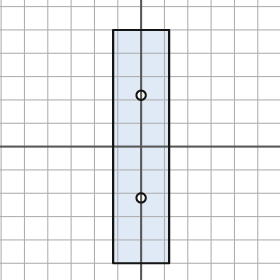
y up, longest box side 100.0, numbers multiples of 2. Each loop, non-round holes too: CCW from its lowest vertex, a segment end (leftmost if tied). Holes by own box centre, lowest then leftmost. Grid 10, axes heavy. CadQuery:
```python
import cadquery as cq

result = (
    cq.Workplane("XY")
    .moveTo(-12.0, -50.0)
    .lineTo(12.0, -50.0)
    .lineTo(12.0, 50.0)
    .lineTo(-12.0, 50.0)
    .close()
    .moveTo(0.0, -22.0)
    .circle(2.0)
    .moveTo(0.0, 22.0)
    .circle(2.0)
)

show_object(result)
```